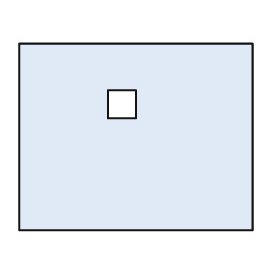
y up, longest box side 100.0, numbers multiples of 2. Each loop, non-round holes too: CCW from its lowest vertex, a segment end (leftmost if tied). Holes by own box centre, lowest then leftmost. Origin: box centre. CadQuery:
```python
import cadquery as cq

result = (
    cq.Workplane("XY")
    .moveTo(-50.0, -40.0)
    .lineTo(50.0, -40.0)
    .lineTo(50.0, 40.0)
    .lineTo(-50.0, 40.0)
    .close()
    .moveTo(-12.0, 8.0)
    .lineTo(0.0, 8.0)
    .lineTo(0.0, 20.0)
    .lineTo(-12.0, 20.0)
    .close()
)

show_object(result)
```